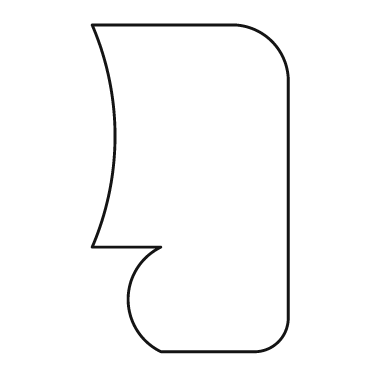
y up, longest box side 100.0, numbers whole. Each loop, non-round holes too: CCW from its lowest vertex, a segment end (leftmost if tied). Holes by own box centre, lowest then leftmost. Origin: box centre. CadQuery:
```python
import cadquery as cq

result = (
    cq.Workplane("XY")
    .moveTo(-9.0, -50.0)
    .lineTo(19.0, -50.0)
    .threePointArc((27.0, -47.0), (30.0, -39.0))
    .lineTo(30.0, 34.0)
    .threePointArc((25.0, 45.0), (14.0, 50.0))
    .lineTo(-30.0, 50.0)
    .threePointArc((-23.0, 16.0), (-30.0, -18.0))
    .lineTo(-9.0, -18.0)
    .threePointArc((-19.0, -34.0), (-9.0, -50.0))
    .close()
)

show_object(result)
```